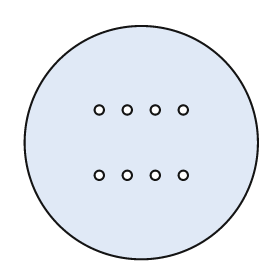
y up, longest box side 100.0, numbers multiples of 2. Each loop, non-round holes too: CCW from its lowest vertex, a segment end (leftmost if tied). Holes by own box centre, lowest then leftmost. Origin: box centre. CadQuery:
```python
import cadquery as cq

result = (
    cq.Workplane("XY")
    .moveTo(0.0, 0.0)
    .circle(50.0)
    .moveTo(-18.0, -14.0)
    .circle(2.0)
    .moveTo(-6.0, -14.0)
    .circle(2.0)
    .moveTo(6.0, -14.0)
    .circle(2.0)
    .moveTo(18.0, -14.0)
    .circle(2.0)
    .moveTo(-18.0, 14.0)
    .circle(2.0)
    .moveTo(-6.0, 14.0)
    .circle(2.0)
    .moveTo(6.0, 14.0)
    .circle(2.0)
    .moveTo(18.0, 14.0)
    .circle(2.0)
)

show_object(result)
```